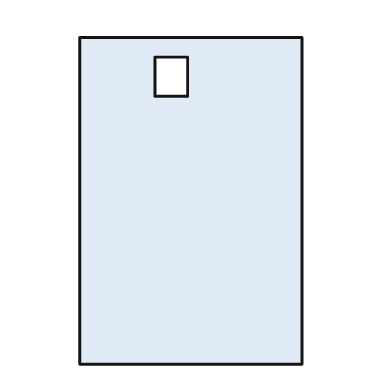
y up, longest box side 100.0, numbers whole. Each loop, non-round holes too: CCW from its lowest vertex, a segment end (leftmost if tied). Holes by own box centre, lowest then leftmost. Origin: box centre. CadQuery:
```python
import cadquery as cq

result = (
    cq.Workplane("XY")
    .moveTo(-34.0, -50.0)
    .lineTo(34.0, -50.0)
    .lineTo(34.0, 50.0)
    .lineTo(-34.0, 50.0)
    .close()
    .moveTo(-11.0, 32.0)
    .lineTo(-1.0, 32.0)
    .lineTo(-1.0, 44.0)
    .lineTo(-11.0, 44.0)
    .close()
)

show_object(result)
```